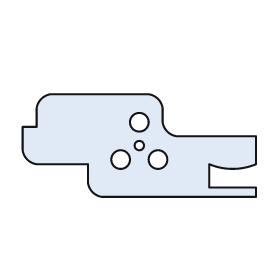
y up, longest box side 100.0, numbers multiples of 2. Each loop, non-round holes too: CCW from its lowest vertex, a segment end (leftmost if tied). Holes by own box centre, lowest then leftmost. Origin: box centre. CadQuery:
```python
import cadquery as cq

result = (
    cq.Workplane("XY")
    .moveTo(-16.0, -22.0)
    .lineTo(50.0, -22.0)
    .lineTo(50.0, -18.0)
    .lineTo(30.0, -18.0)
    .lineTo(30.0, -8.0)
    .threePointArc((40.0, -10.0), (50.0, -8.0))
    .lineTo(50.0, 4.0)
    .lineTo(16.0, 4.0)
    .threePointArc((12.0, 6.0), (10.0, 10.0))
    .lineTo(10.0, 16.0)
    .threePointArc((8.0, 20.0), (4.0, 22.0))
    .lineTo(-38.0, 22.0)
    .threePointArc((-42.0, 20.0), (-44.0, 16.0))
    .lineTo(-44.0, 8.0)
    .lineTo(-50.0, 8.0)
    .lineTo(-50.0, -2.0)
    .threePointArc((-48.0, -6.0), (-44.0, -8.0))
    .lineTo(-22.0, -8.0)
    .lineTo(-22.0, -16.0)
    .threePointArc((-20.0, -20.0), (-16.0, -22.0))
    .close()
    .moveTo(-8.0, -6.0)
    .circle(4.0)
    .moveTo(8.0, -6.0)
    .circle(4.0)
    .moveTo(0.0, 0.0)
    .circle(2.0)
    .moveTo(0.0, 10.0)
    .circle(4.0)
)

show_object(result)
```